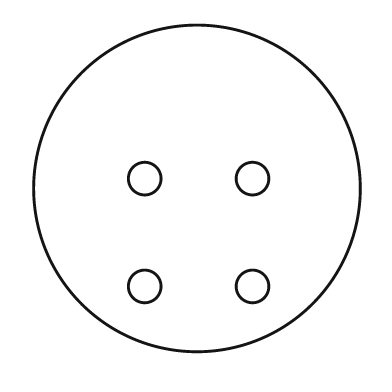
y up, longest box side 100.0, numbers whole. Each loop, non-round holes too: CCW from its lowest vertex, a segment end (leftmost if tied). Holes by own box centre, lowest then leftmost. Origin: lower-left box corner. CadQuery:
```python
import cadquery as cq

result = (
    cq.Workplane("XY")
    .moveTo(50.0, 50.0)
    .circle(50.0)
    .moveTo(34.0, 20.0)
    .circle(5.0)
    .moveTo(67.0, 20.0)
    .circle(5.0)
    .moveTo(34.0, 53.0)
    .circle(5.0)
    .moveTo(67.0, 53.0)
    .circle(5.0)
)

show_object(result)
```